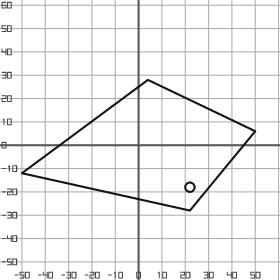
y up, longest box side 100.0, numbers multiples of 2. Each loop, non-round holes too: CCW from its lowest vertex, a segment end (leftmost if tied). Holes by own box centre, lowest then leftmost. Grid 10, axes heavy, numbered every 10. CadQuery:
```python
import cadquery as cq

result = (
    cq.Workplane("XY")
    .moveTo(22.0, -28.0)
    .lineTo(50.0, 6.0)
    .lineTo(4.0, 28.0)
    .lineTo(-50.0, -12.0)
    .close()
    .moveTo(22.0, -18.0)
    .circle(2.0)
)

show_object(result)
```